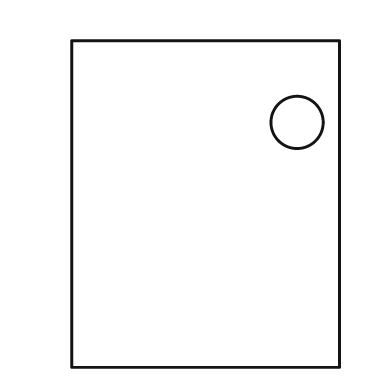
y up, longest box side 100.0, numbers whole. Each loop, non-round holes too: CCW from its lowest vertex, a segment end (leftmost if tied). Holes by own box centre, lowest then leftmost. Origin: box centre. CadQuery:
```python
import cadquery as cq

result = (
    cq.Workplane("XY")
    .moveTo(-41.0, -50.0)
    .lineTo(41.0, -50.0)
    .lineTo(41.0, 50.0)
    .lineTo(-41.0, 50.0)
    .close()
    .moveTo(28.0, 25.0)
    .circle(8.0)
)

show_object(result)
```